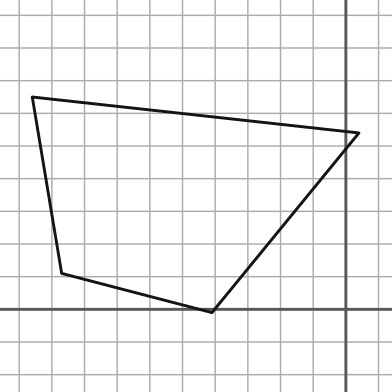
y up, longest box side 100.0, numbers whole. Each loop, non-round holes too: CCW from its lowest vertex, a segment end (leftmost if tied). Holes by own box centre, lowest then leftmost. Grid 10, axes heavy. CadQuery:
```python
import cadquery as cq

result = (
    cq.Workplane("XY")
    .moveTo(-41.0, -1.0)
    .lineTo(4.0, 54.0)
    .lineTo(-96.0, 65.0)
    .lineTo(-87.0, 11.0)
    .close()
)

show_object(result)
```